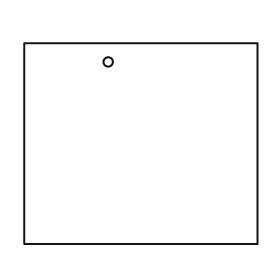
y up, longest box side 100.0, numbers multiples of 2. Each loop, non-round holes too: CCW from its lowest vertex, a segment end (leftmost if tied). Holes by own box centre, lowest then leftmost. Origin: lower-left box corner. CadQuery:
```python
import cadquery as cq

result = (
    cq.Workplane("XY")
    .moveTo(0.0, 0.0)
    .lineTo(100.0, 0.0)
    .lineTo(100.0, 86.0)
    .lineTo(0.0, 86.0)
    .close()
    .moveTo(36.0, 78.0)
    .circle(2.0)
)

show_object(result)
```